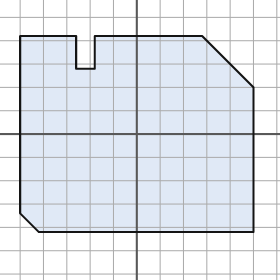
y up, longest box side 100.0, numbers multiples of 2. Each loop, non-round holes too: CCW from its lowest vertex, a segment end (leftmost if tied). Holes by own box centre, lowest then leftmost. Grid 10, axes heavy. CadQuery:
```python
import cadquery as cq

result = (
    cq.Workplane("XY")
    .moveTo(-42.0, -42.0)
    .lineTo(50.0, -42.0)
    .lineTo(50.0, 20.0)
    .lineTo(28.0, 42.0)
    .lineTo(-18.0, 42.0)
    .lineTo(-18.0, 28.0)
    .lineTo(-26.0, 28.0)
    .lineTo(-26.0, 42.0)
    .lineTo(-50.0, 42.0)
    .lineTo(-50.0, -34.0)
    .close()
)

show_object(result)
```